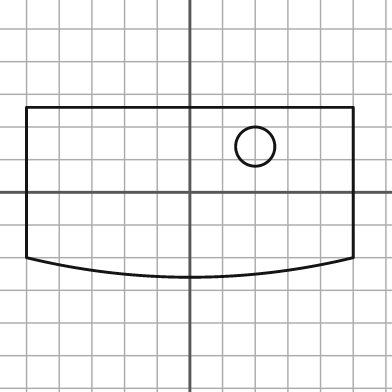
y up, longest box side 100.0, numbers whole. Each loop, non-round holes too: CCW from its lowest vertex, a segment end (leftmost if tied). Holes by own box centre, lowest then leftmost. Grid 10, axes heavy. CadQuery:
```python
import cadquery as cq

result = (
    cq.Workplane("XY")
    .moveTo(-50.0, -20.0)
    .threePointArc((0.0, -26.0), (50.0, -20.0))
    .lineTo(50.0, 26.0)
    .lineTo(-50.0, 26.0)
    .close()
    .moveTo(20.0, 14.0)
    .circle(6.0)
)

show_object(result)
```